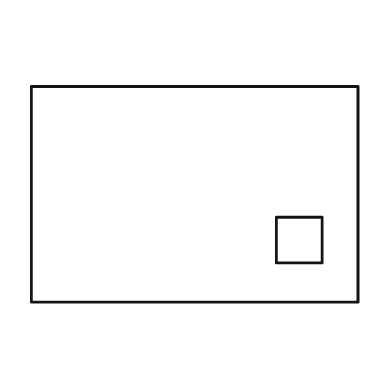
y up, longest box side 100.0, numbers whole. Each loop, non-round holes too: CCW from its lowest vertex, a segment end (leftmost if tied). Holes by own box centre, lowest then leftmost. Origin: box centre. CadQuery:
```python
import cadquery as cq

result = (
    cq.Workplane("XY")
    .moveTo(-50.0, -33.0)
    .lineTo(50.0, -33.0)
    .lineTo(50.0, 33.0)
    .lineTo(-50.0, 33.0)
    .close()
    .moveTo(25.0, -21.0)
    .lineTo(39.0, -21.0)
    .lineTo(39.0, -7.0)
    .lineTo(25.0, -7.0)
    .close()
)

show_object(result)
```